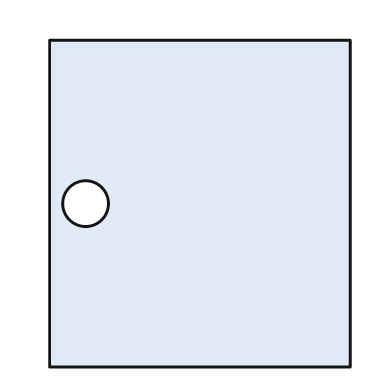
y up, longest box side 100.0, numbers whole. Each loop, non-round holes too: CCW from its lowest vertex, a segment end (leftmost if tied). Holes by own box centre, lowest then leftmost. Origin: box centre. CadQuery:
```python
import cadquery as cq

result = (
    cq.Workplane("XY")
    .moveTo(-46.0, -50.0)
    .lineTo(46.0, -50.0)
    .lineTo(46.0, 50.0)
    .lineTo(-46.0, 50.0)
    .close()
    .moveTo(-35.0, 0.0)
    .circle(7.0)
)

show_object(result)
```